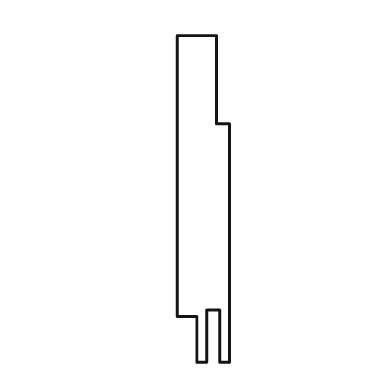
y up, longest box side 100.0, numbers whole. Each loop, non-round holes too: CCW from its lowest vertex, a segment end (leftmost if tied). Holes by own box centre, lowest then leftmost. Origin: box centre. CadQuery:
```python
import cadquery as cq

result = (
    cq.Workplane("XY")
    .moveTo(-2.0, -50.0)
    .lineTo(1.0, -50.0)
    .lineTo(1.0, -34.0)
    .lineTo(5.0, -34.0)
    .lineTo(5.0, -50.0)
    .lineTo(8.0, -50.0)
    .lineTo(8.0, 23.0)
    .lineTo(4.0, 23.0)
    .lineTo(4.0, 50.0)
    .lineTo(-8.0, 50.0)
    .lineTo(-8.0, -36.0)
    .lineTo(-2.0, -36.0)
    .close()
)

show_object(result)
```